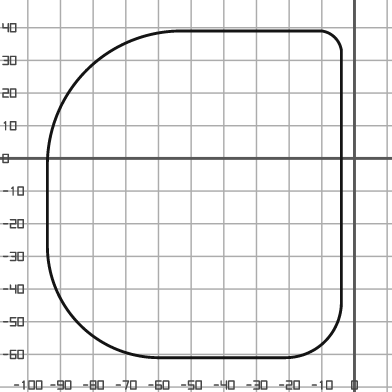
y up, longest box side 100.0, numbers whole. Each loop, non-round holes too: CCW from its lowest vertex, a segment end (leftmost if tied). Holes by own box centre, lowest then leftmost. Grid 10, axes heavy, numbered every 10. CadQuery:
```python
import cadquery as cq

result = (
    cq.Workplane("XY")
    .moveTo(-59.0, -61.0)
    .lineTo(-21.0, -61.0)
    .threePointArc((-9.0, -56.0), (-4.0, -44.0))
    .lineTo(-4.0, 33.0)
    .threePointArc((-6.0, 37.0), (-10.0, 39.0))
    .lineTo(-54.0, 39.0)
    .threePointArc((-82.0, 27.0), (-94.0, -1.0))
    .lineTo(-94.0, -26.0)
    .threePointArc((-84.0, -51.0), (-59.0, -61.0))
    .close()
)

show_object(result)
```